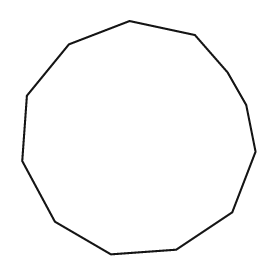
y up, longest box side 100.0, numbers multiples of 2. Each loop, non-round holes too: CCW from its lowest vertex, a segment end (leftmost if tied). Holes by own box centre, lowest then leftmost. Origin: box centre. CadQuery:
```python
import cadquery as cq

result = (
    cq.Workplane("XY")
    .moveTo(-12.0, -50.0)
    .lineTo(16.0, -48.0)
    .lineTo(40.0, -32.0)
    .lineTo(50.0, -6.0)
    .lineTo(46.0, 14.0)
    .lineTo(38.0, 28.0)
    .lineTo(24.0, 44.0)
    .lineTo(-4.0, 50.0)
    .lineTo(-30.0, 40.0)
    .lineTo(-48.0, 18.0)
    .lineTo(-50.0, -10.0)
    .lineTo(-36.0, -36.0)
    .close()
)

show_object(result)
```